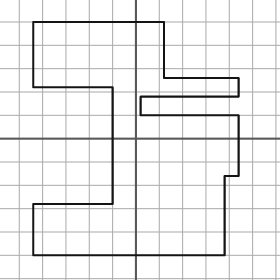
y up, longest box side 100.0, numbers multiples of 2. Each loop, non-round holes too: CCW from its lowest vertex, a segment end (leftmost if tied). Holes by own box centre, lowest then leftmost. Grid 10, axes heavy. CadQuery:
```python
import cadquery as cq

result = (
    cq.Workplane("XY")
    .moveTo(-44.0, -50.0)
    .lineTo(38.0, -50.0)
    .lineTo(38.0, -16.0)
    .lineTo(44.0, -16.0)
    .lineTo(44.0, 10.0)
    .lineTo(2.0, 10.0)
    .lineTo(2.0, 18.0)
    .lineTo(44.0, 18.0)
    .lineTo(44.0, 26.0)
    .lineTo(12.0, 26.0)
    .lineTo(12.0, 50.0)
    .lineTo(-44.0, 50.0)
    .lineTo(-44.0, 22.0)
    .lineTo(-10.0, 22.0)
    .lineTo(-10.0, -28.0)
    .lineTo(-44.0, -28.0)
    .close()
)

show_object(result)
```